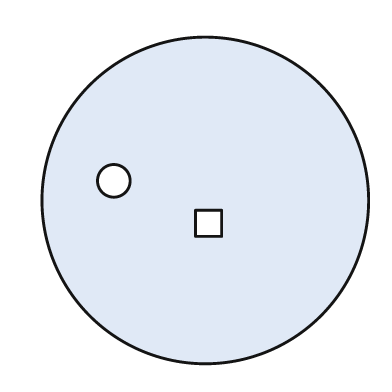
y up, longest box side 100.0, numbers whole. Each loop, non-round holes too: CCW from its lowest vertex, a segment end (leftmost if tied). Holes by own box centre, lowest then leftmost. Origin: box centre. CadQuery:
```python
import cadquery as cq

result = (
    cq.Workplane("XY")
    .moveTo(0.0, 0.0)
    .circle(50.0)
    .moveTo(-3.0, -11.0)
    .lineTo(5.0, -11.0)
    .lineTo(5.0, -3.0)
    .lineTo(-3.0, -3.0)
    .close()
    .moveTo(-28.0, 6.0)
    .circle(5.0)
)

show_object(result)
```